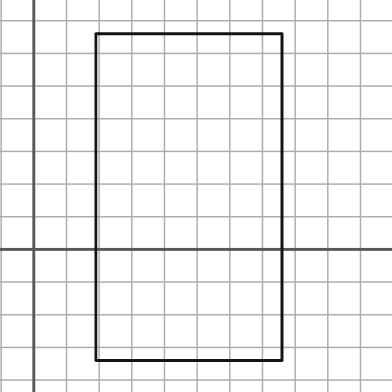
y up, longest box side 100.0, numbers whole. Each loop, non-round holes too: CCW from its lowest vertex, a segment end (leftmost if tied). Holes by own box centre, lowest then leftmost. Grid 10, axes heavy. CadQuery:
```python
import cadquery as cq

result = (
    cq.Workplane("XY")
    .moveTo(19.0, -34.0)
    .lineTo(76.0, -34.0)
    .lineTo(76.0, 66.0)
    .lineTo(19.0, 66.0)
    .close()
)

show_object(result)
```